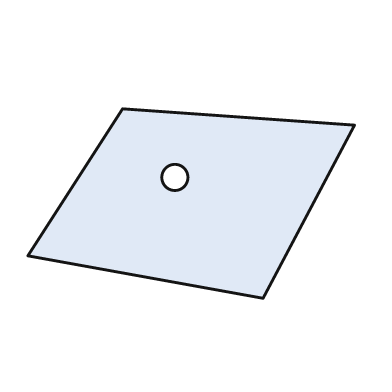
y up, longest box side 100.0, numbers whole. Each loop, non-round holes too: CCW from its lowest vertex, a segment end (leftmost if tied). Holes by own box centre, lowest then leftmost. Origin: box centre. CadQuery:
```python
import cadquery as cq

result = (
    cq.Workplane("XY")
    .moveTo(22.0, -29.0)
    .lineTo(50.0, 24.0)
    .lineTo(-21.0, 29.0)
    .lineTo(-50.0, -16.0)
    .close()
    .moveTo(-5.0, 8.0)
    .circle(4.0)
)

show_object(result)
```